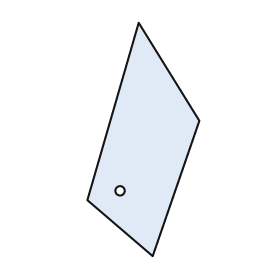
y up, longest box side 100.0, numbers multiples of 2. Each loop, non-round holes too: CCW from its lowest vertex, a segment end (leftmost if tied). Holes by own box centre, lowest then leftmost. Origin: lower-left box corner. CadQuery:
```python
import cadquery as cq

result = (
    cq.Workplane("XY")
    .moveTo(28.0, 0.0)
    .lineTo(48.0, 58.0)
    .lineTo(22.0, 100.0)
    .lineTo(0.0, 24.0)
    .close()
    .moveTo(14.0, 28.0)
    .circle(2.0)
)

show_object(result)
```